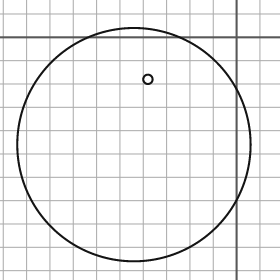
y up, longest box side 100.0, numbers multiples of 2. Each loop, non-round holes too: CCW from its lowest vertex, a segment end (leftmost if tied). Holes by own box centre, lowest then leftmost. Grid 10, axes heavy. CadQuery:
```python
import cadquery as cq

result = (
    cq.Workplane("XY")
    .moveTo(-44.0, -46.0)
    .circle(50.0)
    .moveTo(-38.0, -18.0)
    .circle(2.0)
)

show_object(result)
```